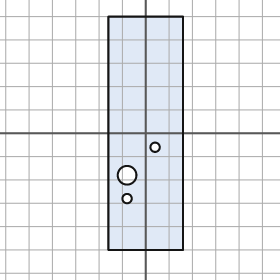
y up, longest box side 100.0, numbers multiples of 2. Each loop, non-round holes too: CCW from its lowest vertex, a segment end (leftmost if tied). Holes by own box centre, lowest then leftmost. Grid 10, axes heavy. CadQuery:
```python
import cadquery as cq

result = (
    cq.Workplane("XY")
    .moveTo(-16.0, -50.0)
    .lineTo(16.0, -50.0)
    .lineTo(16.0, 50.0)
    .lineTo(-16.0, 50.0)
    .close()
    .moveTo(-8.0, -28.0)
    .circle(2.0)
    .moveTo(-8.0, -18.0)
    .circle(4.0)
    .moveTo(4.0, -6.0)
    .circle(2.0)
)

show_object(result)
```